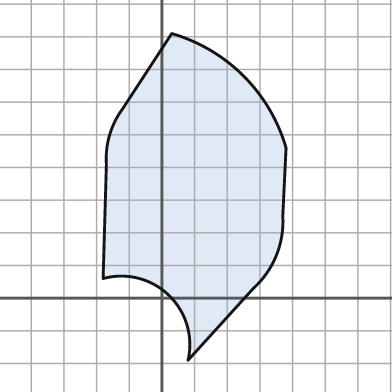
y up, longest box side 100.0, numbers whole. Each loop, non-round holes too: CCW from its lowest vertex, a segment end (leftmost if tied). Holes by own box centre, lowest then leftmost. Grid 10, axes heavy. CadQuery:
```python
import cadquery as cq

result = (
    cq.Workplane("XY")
    .moveTo(8.0, -19.0)
    .lineTo(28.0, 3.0)
    .threePointArc((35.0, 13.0), (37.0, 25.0))
    .lineTo(38.0, 46.0)
    .threePointArc((25.0, 68.0), (3.0, 81.0))
    .lineTo(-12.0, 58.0)
    .threePointArc((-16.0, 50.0), (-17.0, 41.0))
    .lineTo(-18.0, 6.0)
    .threePointArc((2.0, 1.0), (8.0, -19.0))
    .close()
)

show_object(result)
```